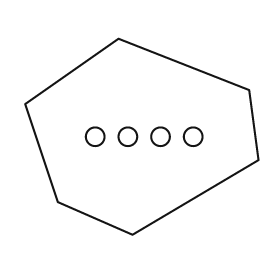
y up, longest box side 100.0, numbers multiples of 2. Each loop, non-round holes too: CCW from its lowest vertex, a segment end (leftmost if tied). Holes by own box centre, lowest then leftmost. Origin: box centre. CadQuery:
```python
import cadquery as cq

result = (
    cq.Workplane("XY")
    .moveTo(-4.0, -42.0)
    .lineTo(50.0, -10.0)
    .lineTo(46.0, 20.0)
    .lineTo(-10.0, 42.0)
    .lineTo(-50.0, 14.0)
    .lineTo(-36.0, -28.0)
    .close()
    .moveTo(-20.0, 0.0)
    .circle(4.0)
    .moveTo(-6.0, 0.0)
    .circle(4.0)
    .moveTo(8.0, 0.0)
    .circle(4.0)
    .moveTo(22.0, 0.0)
    .circle(4.0)
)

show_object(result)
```